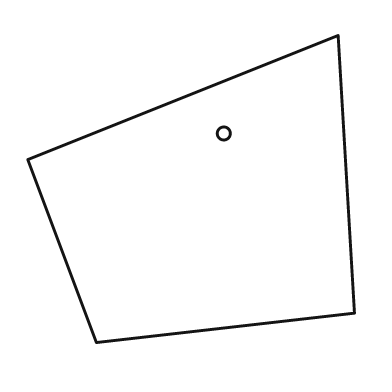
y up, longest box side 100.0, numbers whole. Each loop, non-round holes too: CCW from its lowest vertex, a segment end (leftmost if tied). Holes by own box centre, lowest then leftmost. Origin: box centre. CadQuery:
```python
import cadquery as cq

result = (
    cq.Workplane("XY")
    .moveTo(-29.0, -47.0)
    .lineTo(50.0, -38.0)
    .lineTo(45.0, 47.0)
    .lineTo(-50.0, 9.0)
    .close()
    .moveTo(10.0, 17.0)
    .circle(2.0)
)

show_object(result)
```